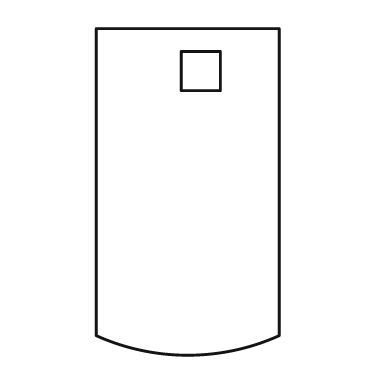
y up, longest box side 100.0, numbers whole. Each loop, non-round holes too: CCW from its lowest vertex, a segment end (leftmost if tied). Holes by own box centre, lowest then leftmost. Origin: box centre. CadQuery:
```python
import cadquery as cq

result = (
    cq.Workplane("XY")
    .moveTo(-28.0, -44.0)
    .threePointArc((0.0, -50.0), (28.0, -44.0))
    .lineTo(28.0, 50.0)
    .lineTo(-28.0, 50.0)
    .close()
    .moveTo(-2.0, 31.0)
    .lineTo(10.0, 31.0)
    .lineTo(10.0, 43.0)
    .lineTo(-2.0, 43.0)
    .close()
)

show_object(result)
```